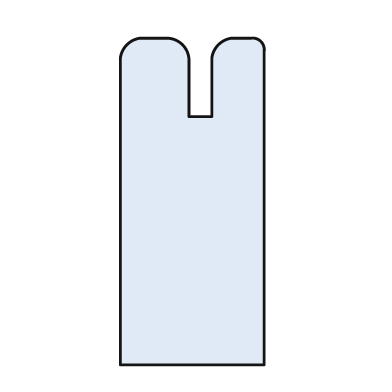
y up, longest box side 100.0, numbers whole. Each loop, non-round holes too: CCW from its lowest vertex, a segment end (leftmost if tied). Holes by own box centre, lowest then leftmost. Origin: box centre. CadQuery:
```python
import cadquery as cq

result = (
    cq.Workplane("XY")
    .moveTo(-22.0, -50.0)
    .lineTo(22.0, -50.0)
    .lineTo(22.0, 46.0)
    .threePointArc((21.0, 49.0), (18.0, 50.0))
    .lineTo(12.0, 50.0)
    .threePointArc((8.0, 48.0), (6.0, 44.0))
    .lineTo(6.0, 26.0)
    .lineTo(-1.0, 26.0)
    .lineTo(-1.0, 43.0)
    .threePointArc((-3.0, 48.0), (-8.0, 50.0))
    .lineTo(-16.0, 50.0)
    .threePointArc((-20.0, 48.0), (-22.0, 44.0))
    .close()
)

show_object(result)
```